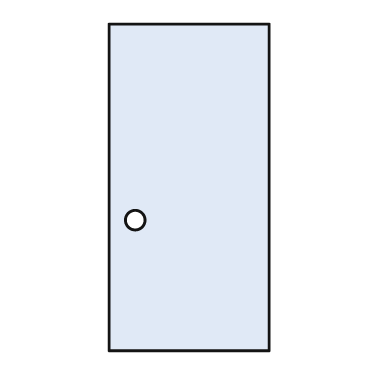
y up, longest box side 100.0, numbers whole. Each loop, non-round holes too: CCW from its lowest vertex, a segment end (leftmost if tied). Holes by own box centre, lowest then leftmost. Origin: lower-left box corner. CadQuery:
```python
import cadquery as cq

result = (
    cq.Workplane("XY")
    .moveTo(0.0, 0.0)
    .lineTo(49.0, 0.0)
    .lineTo(49.0, 100.0)
    .lineTo(0.0, 100.0)
    .close()
    .moveTo(8.0, 40.0)
    .circle(3.0)
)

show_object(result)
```